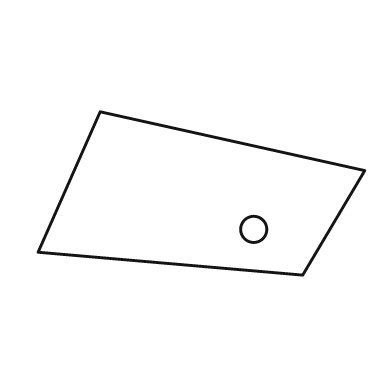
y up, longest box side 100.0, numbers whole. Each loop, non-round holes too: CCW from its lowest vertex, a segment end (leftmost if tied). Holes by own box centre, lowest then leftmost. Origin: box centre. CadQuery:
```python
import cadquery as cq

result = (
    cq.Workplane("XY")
    .moveTo(31.0, -25.0)
    .lineTo(50.0, 7.0)
    .lineTo(-31.0, 25.0)
    .lineTo(-50.0, -18.0)
    .close()
    .moveTo(16.0, -11.0)
    .circle(4.0)
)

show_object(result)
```